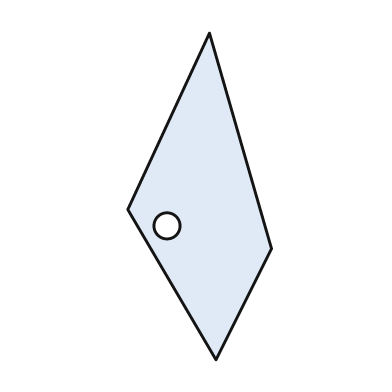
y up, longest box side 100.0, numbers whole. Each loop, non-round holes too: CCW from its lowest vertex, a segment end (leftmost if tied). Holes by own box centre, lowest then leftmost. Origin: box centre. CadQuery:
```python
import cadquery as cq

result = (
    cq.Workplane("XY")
    .moveTo(5.0, -50.0)
    .lineTo(22.0, -16.0)
    .lineTo(3.0, 50.0)
    .lineTo(-22.0, -4.0)
    .close()
    .moveTo(-10.0, -9.0)
    .circle(4.0)
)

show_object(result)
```